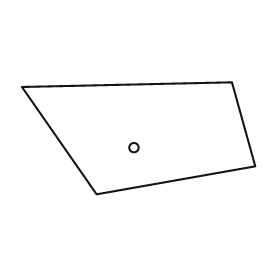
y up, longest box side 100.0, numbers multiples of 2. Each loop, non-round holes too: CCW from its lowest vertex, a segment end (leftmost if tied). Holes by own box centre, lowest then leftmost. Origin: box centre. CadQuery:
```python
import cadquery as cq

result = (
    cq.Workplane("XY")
    .moveTo(-18.0, -24.0)
    .lineTo(50.0, -12.0)
    .lineTo(40.0, 24.0)
    .lineTo(-50.0, 22.0)
    .close()
    .moveTo(-2.0, -4.0)
    .circle(2.0)
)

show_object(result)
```